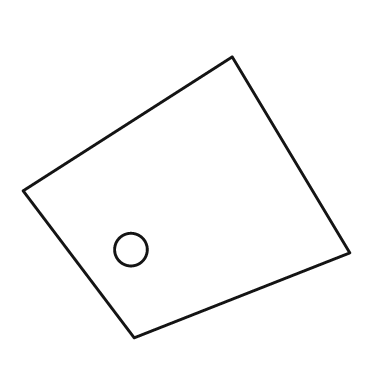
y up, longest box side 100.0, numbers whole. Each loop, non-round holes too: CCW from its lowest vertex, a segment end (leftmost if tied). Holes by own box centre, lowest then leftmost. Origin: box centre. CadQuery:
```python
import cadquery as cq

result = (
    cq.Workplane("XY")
    .moveTo(-16.0, -43.0)
    .lineTo(50.0, -17.0)
    .lineTo(14.0, 43.0)
    .lineTo(-50.0, 2.0)
    .close()
    .moveTo(-17.0, -16.0)
    .circle(5.0)
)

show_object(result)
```